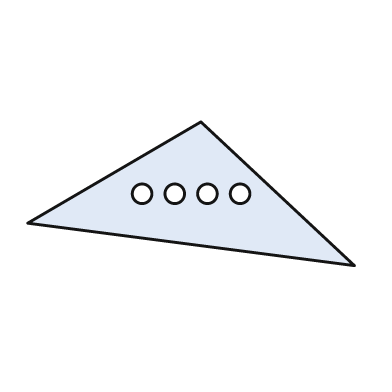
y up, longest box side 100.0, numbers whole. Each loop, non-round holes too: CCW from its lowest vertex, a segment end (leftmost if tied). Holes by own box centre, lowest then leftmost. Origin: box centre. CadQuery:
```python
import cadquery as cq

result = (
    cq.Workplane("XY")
    .moveTo(50.0, -22.0)
    .lineTo(3.0, 22.0)
    .lineTo(-50.0, -9.0)
    .close()
    .moveTo(-15.0, 0.0)
    .circle(3.0)
    .moveTo(-5.0, 0.0)
    .circle(3.0)
    .moveTo(5.0, 0.0)
    .circle(3.0)
    .moveTo(15.0, 0.0)
    .circle(3.0)
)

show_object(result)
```